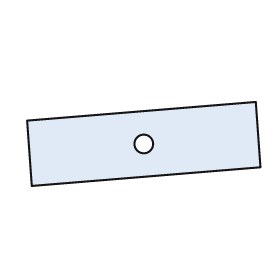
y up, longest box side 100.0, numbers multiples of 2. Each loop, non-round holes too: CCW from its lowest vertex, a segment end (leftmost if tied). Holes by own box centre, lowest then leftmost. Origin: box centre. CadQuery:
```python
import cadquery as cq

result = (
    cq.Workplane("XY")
    .moveTo(-48.0, -18.0)
    .lineTo(50.0, -10.0)
    .lineTo(48.0, 18.0)
    .lineTo(-50.0, 10.0)
    .close()
    .moveTo(0.0, 0.0)
    .circle(4.0)
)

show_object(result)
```